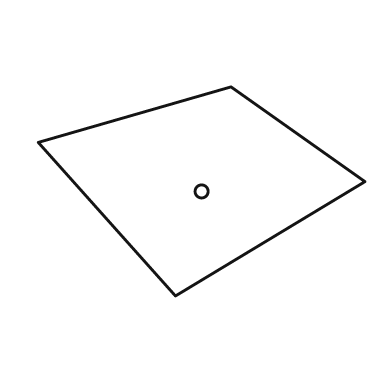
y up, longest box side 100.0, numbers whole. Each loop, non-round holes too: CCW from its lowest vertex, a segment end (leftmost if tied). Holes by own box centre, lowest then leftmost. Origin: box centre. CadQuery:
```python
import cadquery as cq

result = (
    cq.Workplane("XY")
    .moveTo(-8.0, -32.0)
    .lineTo(50.0, 3.0)
    .lineTo(9.0, 32.0)
    .lineTo(-50.0, 15.0)
    .close()
    .moveTo(0.0, 0.0)
    .circle(2.0)
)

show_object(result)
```